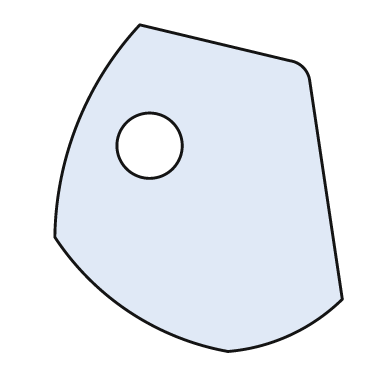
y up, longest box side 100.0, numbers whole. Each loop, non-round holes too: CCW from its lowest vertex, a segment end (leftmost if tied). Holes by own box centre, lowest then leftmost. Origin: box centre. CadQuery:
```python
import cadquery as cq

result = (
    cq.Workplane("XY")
    .moveTo(9.0, -50.0)
    .threePointArc((28.0, -45.0), (44.0, -34.0))
    .lineTo(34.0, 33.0)
    .threePointArc((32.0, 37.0), (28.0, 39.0))
    .lineTo(-18.0, 50.0)
    .threePointArc((-37.0, 20.0), (-44.0, -15.0))
    .threePointArc((-21.0, -38.0), (9.0, -50.0))
    .close()
    .moveTo(-15.0, 13.0)
    .circle(10.0)
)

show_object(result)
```